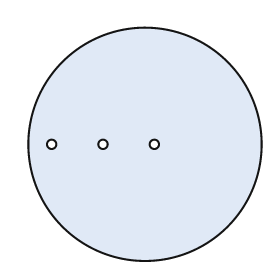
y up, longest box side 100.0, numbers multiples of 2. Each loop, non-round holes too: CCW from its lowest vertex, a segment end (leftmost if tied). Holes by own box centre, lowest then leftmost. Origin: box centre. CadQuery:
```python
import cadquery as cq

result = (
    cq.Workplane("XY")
    .moveTo(0.0, 0.0)
    .circle(50.0)
    .moveTo(-40.0, 0.0)
    .circle(2.0)
    .moveTo(-18.0, 0.0)
    .circle(2.0)
    .moveTo(4.0, 0.0)
    .circle(2.0)
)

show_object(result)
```